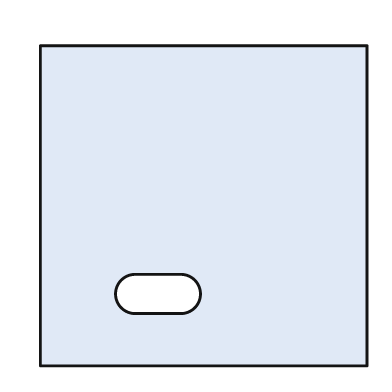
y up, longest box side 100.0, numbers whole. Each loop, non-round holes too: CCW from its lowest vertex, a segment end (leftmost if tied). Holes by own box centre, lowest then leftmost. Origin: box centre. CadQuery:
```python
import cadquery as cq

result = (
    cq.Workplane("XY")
    .moveTo(-50.0, -49.0)
    .lineTo(50.0, -49.0)
    .lineTo(50.0, 49.0)
    .lineTo(-50.0, 49.0)
    .close()
    .moveTo(-21.0, -33.0)
    .lineTo(-7.0, -33.0)
    .threePointArc((-1.0, -27.0), (-7.0, -21.0))
    .lineTo(-21.0, -21.0)
    .threePointArc((-27.0, -27.0), (-21.0, -33.0))
    .close()
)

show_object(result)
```